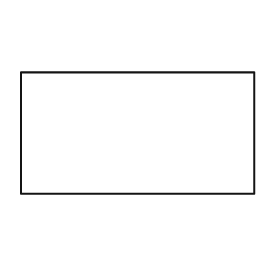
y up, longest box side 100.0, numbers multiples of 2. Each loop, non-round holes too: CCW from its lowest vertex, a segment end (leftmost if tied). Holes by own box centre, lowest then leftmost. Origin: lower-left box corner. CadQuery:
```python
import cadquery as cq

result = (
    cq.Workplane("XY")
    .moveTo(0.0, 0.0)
    .lineTo(100.0, 0.0)
    .lineTo(100.0, 52.0)
    .lineTo(0.0, 52.0)
    .close()
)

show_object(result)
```